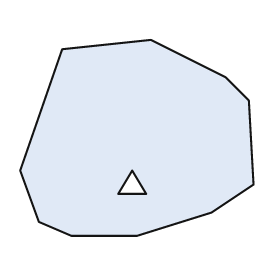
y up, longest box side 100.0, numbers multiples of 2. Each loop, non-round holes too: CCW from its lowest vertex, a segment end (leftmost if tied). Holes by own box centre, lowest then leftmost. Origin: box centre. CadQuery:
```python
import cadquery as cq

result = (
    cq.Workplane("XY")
    .moveTo(-28.0, -42.0)
    .lineTo(0.0, -42.0)
    .lineTo(32.0, -32.0)
    .lineTo(50.0, -20.0)
    .lineTo(48.0, 16.0)
    .lineTo(38.0, 26.0)
    .lineTo(6.0, 42.0)
    .lineTo(-32.0, 38.0)
    .lineTo(-50.0, -14.0)
    .lineTo(-42.0, -36.0)
    .close()
    .moveTo(-8.0, -24.0)
    .lineTo(4.0, -24.0)
    .lineTo(-2.0, -14.0)
    .close()
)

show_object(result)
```